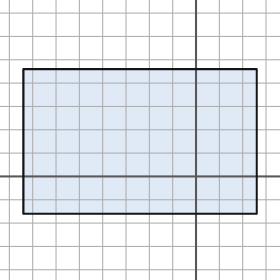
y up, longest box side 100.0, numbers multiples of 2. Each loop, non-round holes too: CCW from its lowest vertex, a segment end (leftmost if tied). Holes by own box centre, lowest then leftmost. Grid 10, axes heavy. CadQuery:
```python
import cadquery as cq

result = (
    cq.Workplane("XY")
    .moveTo(-74.0, -16.0)
    .lineTo(26.0, -16.0)
    .lineTo(26.0, 46.0)
    .lineTo(-74.0, 46.0)
    .close()
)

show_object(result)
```